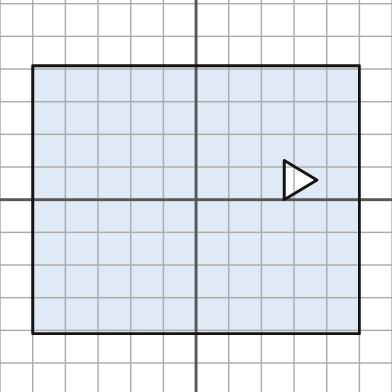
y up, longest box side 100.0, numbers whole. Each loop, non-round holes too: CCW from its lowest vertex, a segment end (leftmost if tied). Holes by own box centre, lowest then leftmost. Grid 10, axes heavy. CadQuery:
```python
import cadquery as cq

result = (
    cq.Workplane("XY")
    .moveTo(-50.0, -41.0)
    .lineTo(50.0, -41.0)
    .lineTo(50.0, 41.0)
    .lineTo(-50.0, 41.0)
    .close()
    .moveTo(27.0, 0.0)
    .lineTo(37.0, 6.0)
    .lineTo(27.0, 12.0)
    .close()
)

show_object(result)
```